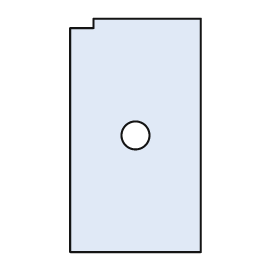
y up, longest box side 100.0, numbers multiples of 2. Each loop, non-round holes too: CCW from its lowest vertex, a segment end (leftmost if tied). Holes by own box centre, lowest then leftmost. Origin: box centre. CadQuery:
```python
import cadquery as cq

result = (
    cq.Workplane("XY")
    .moveTo(-28.0, -50.0)
    .lineTo(28.0, -50.0)
    .lineTo(28.0, 50.0)
    .lineTo(-18.0, 50.0)
    .lineTo(-18.0, 46.0)
    .lineTo(-28.0, 46.0)
    .close()
    .moveTo(0.0, 0.0)
    .circle(6.0)
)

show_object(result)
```